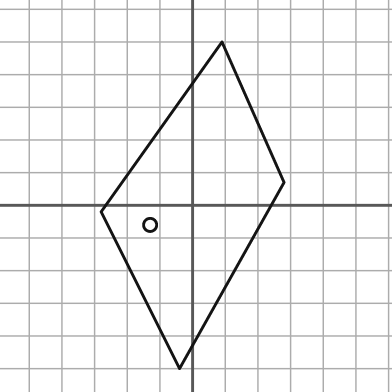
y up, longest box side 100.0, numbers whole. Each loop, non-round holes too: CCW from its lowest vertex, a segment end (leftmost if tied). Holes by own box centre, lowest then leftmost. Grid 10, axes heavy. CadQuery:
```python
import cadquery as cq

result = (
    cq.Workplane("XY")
    .moveTo(-4.0, -50.0)
    .lineTo(28.0, 7.0)
    .lineTo(9.0, 50.0)
    .lineTo(-28.0, -2.0)
    .close()
    .moveTo(-13.0, -6.0)
    .circle(2.0)
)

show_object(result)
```